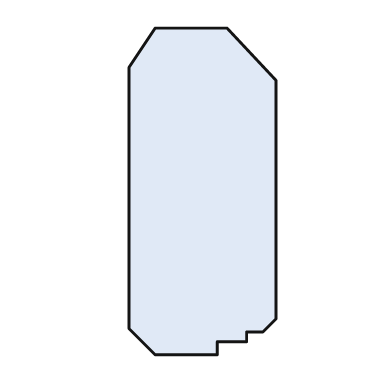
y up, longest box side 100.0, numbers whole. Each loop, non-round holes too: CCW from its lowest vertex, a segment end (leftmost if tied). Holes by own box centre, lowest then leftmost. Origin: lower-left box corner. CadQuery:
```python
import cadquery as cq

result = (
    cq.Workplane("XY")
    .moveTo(8.0, 0.0)
    .lineTo(27.0, 0.0)
    .lineTo(27.0, 4.0)
    .lineTo(36.0, 4.0)
    .lineTo(36.0, 7.0)
    .lineTo(41.0, 7.0)
    .lineTo(45.0, 11.0)
    .lineTo(45.0, 84.0)
    .lineTo(30.0, 100.0)
    .lineTo(8.0, 100.0)
    .lineTo(0.0, 88.0)
    .lineTo(0.0, 8.0)
    .close()
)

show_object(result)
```